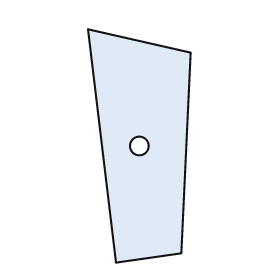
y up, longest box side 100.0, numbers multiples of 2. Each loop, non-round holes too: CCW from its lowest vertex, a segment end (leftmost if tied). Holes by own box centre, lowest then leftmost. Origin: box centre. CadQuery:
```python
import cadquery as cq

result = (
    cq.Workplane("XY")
    .moveTo(-10.0, -50.0)
    .lineTo(18.0, -46.0)
    .lineTo(22.0, 40.0)
    .lineTo(-22.0, 50.0)
    .close()
    .moveTo(0.0, 0.0)
    .circle(4.0)
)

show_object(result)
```